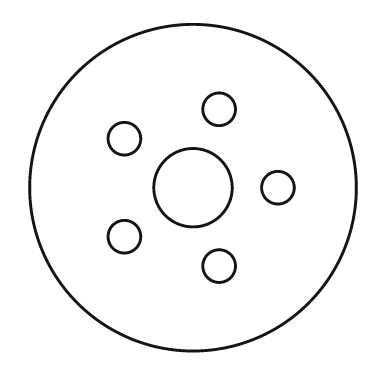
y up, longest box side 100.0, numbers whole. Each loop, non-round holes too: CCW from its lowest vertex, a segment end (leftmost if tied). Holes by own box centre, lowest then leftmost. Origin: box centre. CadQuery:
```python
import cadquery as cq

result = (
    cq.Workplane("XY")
    .moveTo(0.0, 0.0)
    .circle(50.0)
    .moveTo(8.0, -24.0)
    .circle(5.0)
    .moveTo(-21.0, -15.0)
    .circle(5.0)
    .moveTo(0.0, 0.0)
    .circle(12.0)
    .moveTo(26.0, 0.0)
    .circle(5.0)
    .moveTo(-21.0, 15.0)
    .circle(5.0)
    .moveTo(8.0, 24.0)
    .circle(5.0)
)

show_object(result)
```